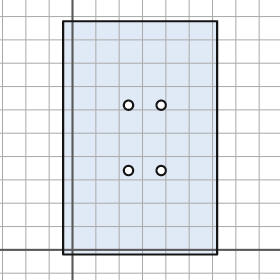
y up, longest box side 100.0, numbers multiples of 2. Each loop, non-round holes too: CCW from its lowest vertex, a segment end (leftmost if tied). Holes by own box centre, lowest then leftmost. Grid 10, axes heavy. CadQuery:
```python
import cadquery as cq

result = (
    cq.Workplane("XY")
    .moveTo(-4.0, -2.0)
    .lineTo(62.0, -2.0)
    .lineTo(62.0, 98.0)
    .lineTo(-4.0, 98.0)
    .close()
    .moveTo(24.0, 34.0)
    .circle(2.0)
    .moveTo(38.0, 34.0)
    .circle(2.0)
    .moveTo(24.0, 62.0)
    .circle(2.0)
    .moveTo(38.0, 62.0)
    .circle(2.0)
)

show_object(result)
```